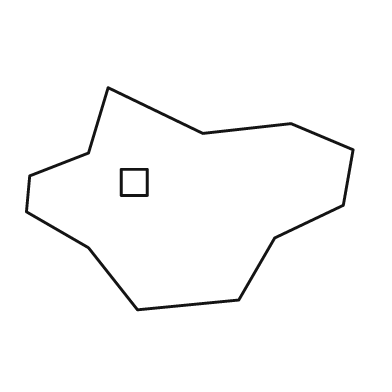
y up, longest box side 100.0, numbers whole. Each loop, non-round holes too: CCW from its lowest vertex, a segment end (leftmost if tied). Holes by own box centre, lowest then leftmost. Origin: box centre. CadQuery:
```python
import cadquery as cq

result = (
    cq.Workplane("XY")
    .moveTo(-16.0, -34.0)
    .lineTo(15.0, -31.0)
    .lineTo(26.0, -12.0)
    .lineTo(47.0, -2.0)
    .lineTo(50.0, 15.0)
    .lineTo(31.0, 23.0)
    .lineTo(4.0, 20.0)
    .lineTo(-25.0, 34.0)
    .lineTo(-31.0, 14.0)
    .lineTo(-49.0, 7.0)
    .lineTo(-50.0, -4.0)
    .lineTo(-31.0, -15.0)
    .close()
    .moveTo(-21.0, 1.0)
    .lineTo(-13.0, 1.0)
    .lineTo(-13.0, 9.0)
    .lineTo(-21.0, 9.0)
    .close()
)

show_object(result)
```